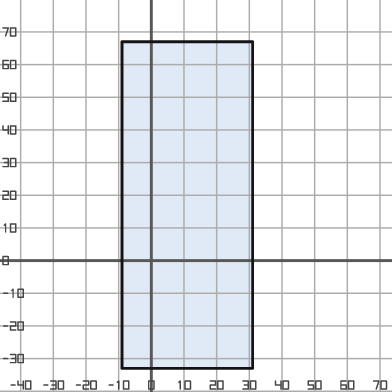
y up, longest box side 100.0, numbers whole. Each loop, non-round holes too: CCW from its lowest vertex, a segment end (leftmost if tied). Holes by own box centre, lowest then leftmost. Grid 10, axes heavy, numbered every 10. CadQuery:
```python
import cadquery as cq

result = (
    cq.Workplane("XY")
    .moveTo(-9.0, -33.0)
    .lineTo(31.0, -33.0)
    .lineTo(31.0, 67.0)
    .lineTo(-9.0, 67.0)
    .close()
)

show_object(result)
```